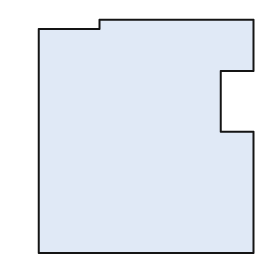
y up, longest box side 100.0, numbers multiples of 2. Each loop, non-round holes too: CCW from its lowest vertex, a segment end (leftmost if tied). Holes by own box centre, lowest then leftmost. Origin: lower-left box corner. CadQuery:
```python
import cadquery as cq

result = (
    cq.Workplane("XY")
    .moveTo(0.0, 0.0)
    .lineTo(92.0, 0.0)
    .lineTo(92.0, 52.0)
    .lineTo(78.0, 52.0)
    .lineTo(78.0, 78.0)
    .lineTo(92.0, 78.0)
    .lineTo(92.0, 100.0)
    .lineTo(26.0, 100.0)
    .lineTo(26.0, 96.0)
    .lineTo(0.0, 96.0)
    .close()
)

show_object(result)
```